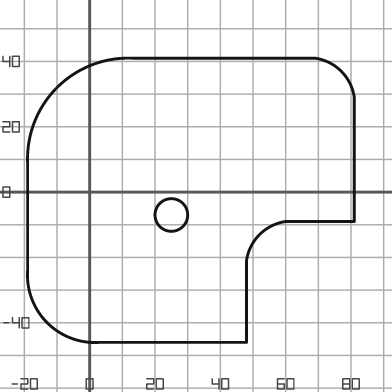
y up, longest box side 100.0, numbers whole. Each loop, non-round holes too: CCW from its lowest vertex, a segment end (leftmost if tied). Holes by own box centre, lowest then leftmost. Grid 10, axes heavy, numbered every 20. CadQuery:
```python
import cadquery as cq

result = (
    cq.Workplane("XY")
    .moveTo(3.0, -46.0)
    .lineTo(48.0, -46.0)
    .lineTo(48.0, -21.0)
    .threePointArc((52.0, -13.0), (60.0, -9.0))
    .lineTo(81.0, -9.0)
    .lineTo(81.0, 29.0)
    .threePointArc((77.0, 37.0), (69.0, 41.0))
    .lineTo(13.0, 41.0)
    .threePointArc((-10.0, 32.0), (-19.0, 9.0))
    .lineTo(-19.0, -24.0)
    .threePointArc((-13.0, -40.0), (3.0, -46.0))
    .close()
    .moveTo(25.0, -7.0)
    .circle(5.0)
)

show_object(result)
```